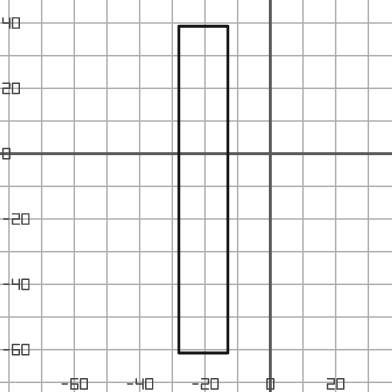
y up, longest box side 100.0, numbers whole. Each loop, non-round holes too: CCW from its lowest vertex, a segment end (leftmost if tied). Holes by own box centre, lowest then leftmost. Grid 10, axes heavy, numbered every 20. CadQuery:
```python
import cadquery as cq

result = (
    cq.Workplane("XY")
    .moveTo(-28.0, -61.0)
    .lineTo(-13.0, -61.0)
    .lineTo(-13.0, 39.0)
    .lineTo(-28.0, 39.0)
    .close()
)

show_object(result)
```